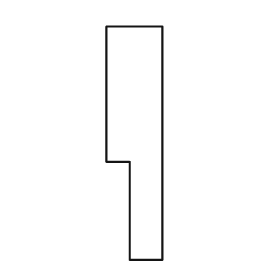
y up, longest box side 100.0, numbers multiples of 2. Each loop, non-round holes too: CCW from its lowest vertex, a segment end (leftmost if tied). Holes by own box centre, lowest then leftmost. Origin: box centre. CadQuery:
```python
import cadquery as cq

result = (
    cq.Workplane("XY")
    .moveTo(-2.0, -50.0)
    .lineTo(12.0, -50.0)
    .lineTo(12.0, 50.0)
    .lineTo(-12.0, 50.0)
    .lineTo(-12.0, -8.0)
    .lineTo(-2.0, -8.0)
    .close()
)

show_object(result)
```